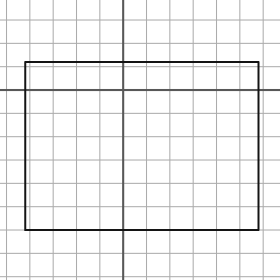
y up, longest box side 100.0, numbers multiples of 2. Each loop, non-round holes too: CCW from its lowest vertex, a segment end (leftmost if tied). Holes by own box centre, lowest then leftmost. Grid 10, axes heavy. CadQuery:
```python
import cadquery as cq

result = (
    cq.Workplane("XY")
    .moveTo(-42.0, -60.0)
    .lineTo(58.0, -60.0)
    .lineTo(58.0, 12.0)
    .lineTo(-42.0, 12.0)
    .close()
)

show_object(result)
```